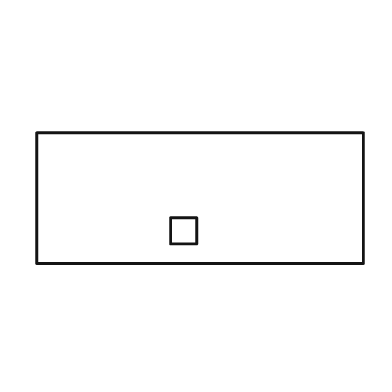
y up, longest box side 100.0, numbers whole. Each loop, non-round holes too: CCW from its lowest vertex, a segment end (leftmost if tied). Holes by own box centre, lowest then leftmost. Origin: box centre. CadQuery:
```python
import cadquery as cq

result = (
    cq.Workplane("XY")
    .moveTo(-50.0, -20.0)
    .lineTo(50.0, -20.0)
    .lineTo(50.0, 20.0)
    .lineTo(-50.0, 20.0)
    .close()
    .moveTo(-9.0, -14.0)
    .lineTo(-1.0, -14.0)
    .lineTo(-1.0, -6.0)
    .lineTo(-9.0, -6.0)
    .close()
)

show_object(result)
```